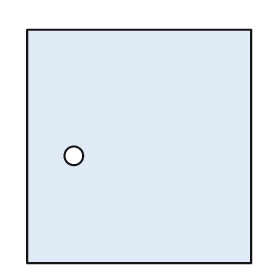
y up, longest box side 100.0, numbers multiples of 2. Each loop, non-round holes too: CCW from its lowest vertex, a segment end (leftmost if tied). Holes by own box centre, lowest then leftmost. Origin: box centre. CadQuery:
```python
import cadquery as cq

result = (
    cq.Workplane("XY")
    .moveTo(-48.0, -50.0)
    .lineTo(48.0, -50.0)
    .lineTo(48.0, 50.0)
    .lineTo(-48.0, 50.0)
    .close()
    .moveTo(-28.0, -4.0)
    .circle(4.0)
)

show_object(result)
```